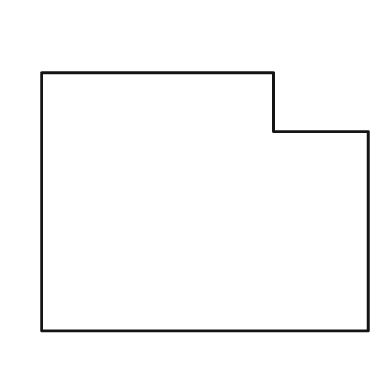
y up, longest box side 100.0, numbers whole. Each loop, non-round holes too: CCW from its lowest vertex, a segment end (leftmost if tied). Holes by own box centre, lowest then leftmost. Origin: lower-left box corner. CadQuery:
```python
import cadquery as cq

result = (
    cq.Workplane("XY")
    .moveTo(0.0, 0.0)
    .lineTo(100.0, 0.0)
    .lineTo(100.0, 61.0)
    .lineTo(71.0, 61.0)
    .lineTo(71.0, 79.0)
    .lineTo(0.0, 79.0)
    .close()
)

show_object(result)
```